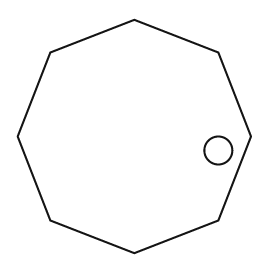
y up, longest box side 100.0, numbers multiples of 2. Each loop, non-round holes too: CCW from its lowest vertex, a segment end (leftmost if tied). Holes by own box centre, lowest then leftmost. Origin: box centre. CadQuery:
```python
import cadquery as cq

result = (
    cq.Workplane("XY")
    .moveTo(0.0, -50.0)
    .lineTo(36.0, -36.0)
    .lineTo(50.0, 0.0)
    .lineTo(36.0, 36.0)
    .lineTo(0.0, 50.0)
    .lineTo(-36.0, 36.0)
    .lineTo(-50.0, 0.0)
    .lineTo(-36.0, -36.0)
    .close()
    .moveTo(36.0, -6.0)
    .circle(6.0)
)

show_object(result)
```